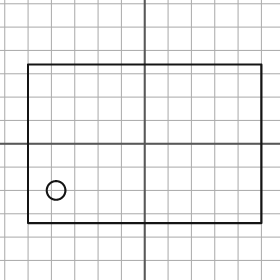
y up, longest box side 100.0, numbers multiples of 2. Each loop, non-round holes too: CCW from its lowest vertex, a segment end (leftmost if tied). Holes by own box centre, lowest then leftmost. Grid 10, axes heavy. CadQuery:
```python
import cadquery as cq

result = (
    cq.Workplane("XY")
    .moveTo(-50.0, -34.0)
    .lineTo(50.0, -34.0)
    .lineTo(50.0, 34.0)
    .lineTo(-50.0, 34.0)
    .close()
    .moveTo(-38.0, -20.0)
    .circle(4.0)
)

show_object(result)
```